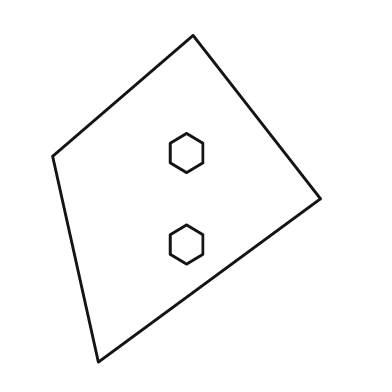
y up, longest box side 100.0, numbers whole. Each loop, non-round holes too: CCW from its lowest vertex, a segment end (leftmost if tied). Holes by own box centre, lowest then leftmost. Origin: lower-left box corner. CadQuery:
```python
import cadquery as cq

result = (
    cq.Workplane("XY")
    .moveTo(14.0, 0.0)
    .lineTo(82.0, 50.0)
    .lineTo(43.0, 100.0)
    .lineTo(0.0, 63.0)
    .close()
    .moveTo(41.0, 30.0)
    .lineTo(46.0, 33.0)
    .lineTo(46.0, 39.0)
    .lineTo(41.0, 42.0)
    .lineTo(36.0, 39.0)
    .lineTo(36.0, 33.0)
    .close()
    .moveTo(41.0, 58.0)
    .lineTo(46.0, 61.0)
    .lineTo(46.0, 67.0)
    .lineTo(41.0, 70.0)
    .lineTo(36.0, 67.0)
    .lineTo(36.0, 61.0)
    .close()
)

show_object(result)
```